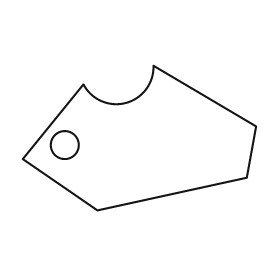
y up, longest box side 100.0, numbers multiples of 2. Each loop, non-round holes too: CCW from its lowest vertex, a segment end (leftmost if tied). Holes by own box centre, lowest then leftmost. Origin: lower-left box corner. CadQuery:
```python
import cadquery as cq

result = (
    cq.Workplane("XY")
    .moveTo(32.0, 0.0)
    .lineTo(96.0, 14.0)
    .lineTo(100.0, 36.0)
    .lineTo(56.0, 62.0)
    .threePointArc((44.0, 46.0), (26.0, 54.0))
    .lineTo(0.0, 22.0)
    .close()
    .moveTo(18.0, 28.0)
    .circle(6.0)
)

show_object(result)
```